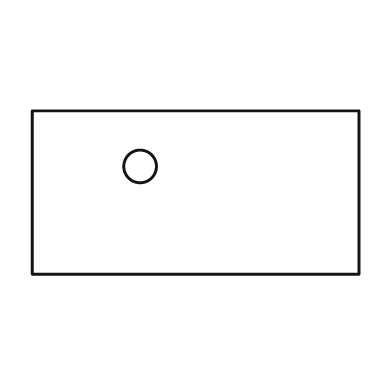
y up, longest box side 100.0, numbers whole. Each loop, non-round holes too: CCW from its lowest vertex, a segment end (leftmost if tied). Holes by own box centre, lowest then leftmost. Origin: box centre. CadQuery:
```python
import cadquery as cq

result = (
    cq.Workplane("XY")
    .moveTo(-50.0, -25.0)
    .lineTo(50.0, -25.0)
    .lineTo(50.0, 25.0)
    .lineTo(-50.0, 25.0)
    .close()
    .moveTo(-17.0, 8.0)
    .circle(5.0)
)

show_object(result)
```